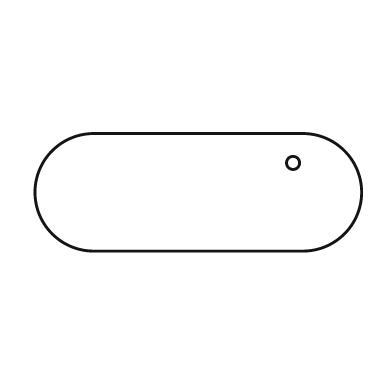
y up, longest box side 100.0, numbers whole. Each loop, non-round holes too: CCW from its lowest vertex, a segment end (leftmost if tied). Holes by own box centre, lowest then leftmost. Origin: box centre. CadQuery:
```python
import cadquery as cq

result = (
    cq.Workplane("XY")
    .moveTo(-32.0, -18.0)
    .lineTo(32.0, -18.0)
    .threePointArc((50.0, 0.0), (32.0, 18.0))
    .lineTo(-32.0, 18.0)
    .threePointArc((-50.0, 0.0), (-32.0, -18.0))
    .close()
    .moveTo(29.0, 9.0)
    .circle(2.0)
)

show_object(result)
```